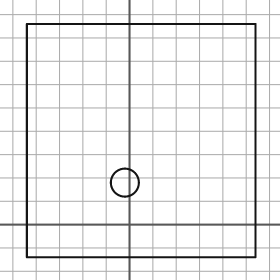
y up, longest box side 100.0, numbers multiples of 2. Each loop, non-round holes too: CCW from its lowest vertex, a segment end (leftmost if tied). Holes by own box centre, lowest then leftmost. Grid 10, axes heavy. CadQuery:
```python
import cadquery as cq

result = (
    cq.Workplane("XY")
    .moveTo(-44.0, -14.0)
    .lineTo(54.0, -14.0)
    .lineTo(54.0, 86.0)
    .lineTo(-44.0, 86.0)
    .close()
    .moveTo(-2.0, 18.0)
    .circle(6.0)
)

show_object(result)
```